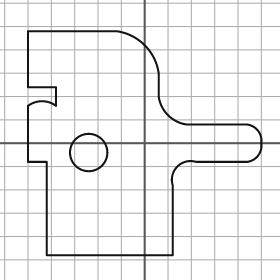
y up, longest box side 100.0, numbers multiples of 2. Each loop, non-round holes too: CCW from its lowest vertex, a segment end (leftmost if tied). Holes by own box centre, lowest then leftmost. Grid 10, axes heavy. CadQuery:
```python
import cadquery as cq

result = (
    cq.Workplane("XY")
    .moveTo(-42.0, -48.0)
    .lineTo(12.0, -48.0)
    .lineTo(12.0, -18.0)
    .threePointArc((14.0, -10.0), (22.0, -8.0))
    .lineTo(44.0, -8.0)
    .threePointArc((48.0, -6.0), (50.0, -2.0))
    .lineTo(50.0, 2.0)
    .threePointArc((48.0, 6.0), (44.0, 8.0))
    .lineTo(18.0, 8.0)
    .threePointArc((10.0, 12.0), (6.0, 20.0))
    .lineTo(6.0, 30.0)
    .threePointArc((0.0, 42.0), (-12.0, 48.0))
    .lineTo(-50.0, 48.0)
    .lineTo(-50.0, 24.0)
    .lineTo(-38.0, 24.0)
    .lineTo(-38.0, 16.0)
    .threePointArc((-44.0, 18.0), (-50.0, 16.0))
    .lineTo(-50.0, -8.0)
    .lineTo(-42.0, -8.0)
    .close()
    .moveTo(-24.0, -4.0)
    .circle(8.0)
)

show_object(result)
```